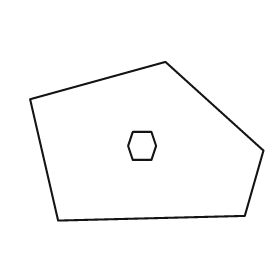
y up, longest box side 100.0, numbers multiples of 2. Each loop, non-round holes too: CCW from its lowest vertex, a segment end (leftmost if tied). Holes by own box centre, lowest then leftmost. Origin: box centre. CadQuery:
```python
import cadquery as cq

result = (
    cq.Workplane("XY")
    .moveTo(-38.0, -34.0)
    .lineTo(42.0, -32.0)
    .lineTo(50.0, -4.0)
    .lineTo(8.0, 34.0)
    .lineTo(-50.0, 18.0)
    .close()
    .moveTo(-6.0, -8.0)
    .lineTo(2.0, -8.0)
    .lineTo(4.0, -2.0)
    .lineTo(2.0, 4.0)
    .lineTo(-6.0, 4.0)
    .lineTo(-8.0, -2.0)
    .close()
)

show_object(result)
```